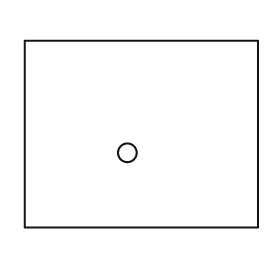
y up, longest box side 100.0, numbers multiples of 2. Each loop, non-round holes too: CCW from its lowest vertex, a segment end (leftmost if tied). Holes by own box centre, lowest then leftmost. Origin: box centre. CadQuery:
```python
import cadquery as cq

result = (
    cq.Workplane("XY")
    .moveTo(-50.0, -40.0)
    .lineTo(50.0, -40.0)
    .lineTo(50.0, 40.0)
    .lineTo(-50.0, 40.0)
    .close()
    .moveTo(-6.0, -8.0)
    .circle(4.0)
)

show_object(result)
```